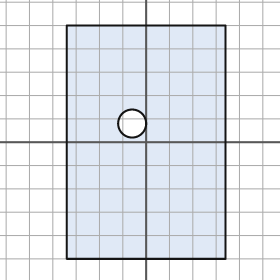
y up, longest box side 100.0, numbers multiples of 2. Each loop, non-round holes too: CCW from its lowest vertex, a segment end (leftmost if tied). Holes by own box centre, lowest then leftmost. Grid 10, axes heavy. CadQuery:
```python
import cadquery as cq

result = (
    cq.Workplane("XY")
    .moveTo(-34.0, -50.0)
    .lineTo(34.0, -50.0)
    .lineTo(34.0, 50.0)
    .lineTo(-34.0, 50.0)
    .close()
    .moveTo(-6.0, 8.0)
    .circle(6.0)
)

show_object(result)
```